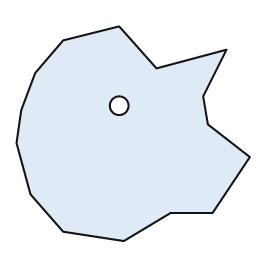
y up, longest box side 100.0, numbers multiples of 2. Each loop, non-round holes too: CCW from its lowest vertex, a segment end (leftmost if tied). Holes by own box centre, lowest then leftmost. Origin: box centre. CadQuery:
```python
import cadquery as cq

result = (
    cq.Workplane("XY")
    .moveTo(-4.0, -46.0)
    .lineTo(16.0, -34.0)
    .lineTo(34.0, -34.0)
    .lineTo(50.0, -10.0)
    .lineTo(32.0, 4.0)
    .lineTo(30.0, 16.0)
    .lineTo(40.0, 36.0)
    .lineTo(10.0, 28.0)
    .lineTo(-6.0, 46.0)
    .lineTo(-30.0, 40.0)
    .lineTo(-42.0, 26.0)
    .lineTo(-48.0, 10.0)
    .lineTo(-50.0, -4.0)
    .lineTo(-44.0, -26.0)
    .lineTo(-30.0, -42.0)
    .close()
    .moveTo(-6.0, 12.0)
    .circle(4.0)
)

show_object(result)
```